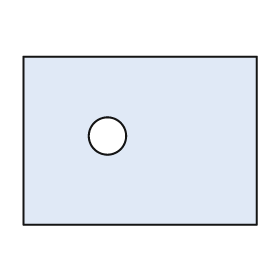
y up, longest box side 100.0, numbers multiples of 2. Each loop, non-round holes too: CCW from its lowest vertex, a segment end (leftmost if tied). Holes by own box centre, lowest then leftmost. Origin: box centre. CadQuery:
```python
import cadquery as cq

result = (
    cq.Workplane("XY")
    .moveTo(-50.0, -36.0)
    .lineTo(50.0, -36.0)
    .lineTo(50.0, 36.0)
    .lineTo(-50.0, 36.0)
    .close()
    .moveTo(-14.0, 2.0)
    .circle(8.0)
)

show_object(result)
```